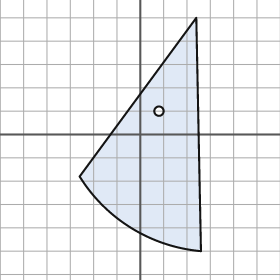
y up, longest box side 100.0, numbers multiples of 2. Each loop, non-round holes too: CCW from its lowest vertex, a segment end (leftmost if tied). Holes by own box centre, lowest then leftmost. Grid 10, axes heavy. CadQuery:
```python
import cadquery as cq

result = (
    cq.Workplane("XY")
    .moveTo(26.0, -50.0)
    .lineTo(24.0, 50.0)
    .lineTo(-26.0, -18.0)
    .threePointArc((-4.0, -40.0), (26.0, -50.0))
    .close()
    .moveTo(8.0, 10.0)
    .circle(2.0)
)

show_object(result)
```